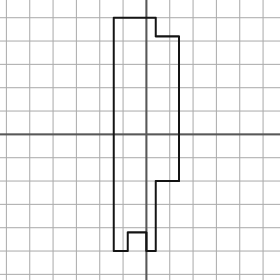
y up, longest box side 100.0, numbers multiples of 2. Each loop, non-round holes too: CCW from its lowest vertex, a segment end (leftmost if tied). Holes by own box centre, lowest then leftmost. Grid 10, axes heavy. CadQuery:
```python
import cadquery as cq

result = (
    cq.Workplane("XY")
    .moveTo(-14.0, -50.0)
    .lineTo(-8.0, -50.0)
    .lineTo(-8.0, -42.0)
    .lineTo(0.0, -42.0)
    .lineTo(0.0, -50.0)
    .lineTo(4.0, -50.0)
    .lineTo(4.0, -20.0)
    .lineTo(14.0, -20.0)
    .lineTo(14.0, 42.0)
    .lineTo(4.0, 42.0)
    .lineTo(4.0, 50.0)
    .lineTo(-14.0, 50.0)
    .close()
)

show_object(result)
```